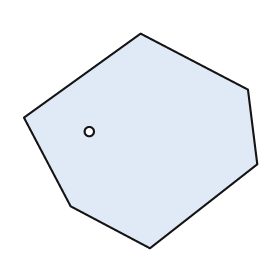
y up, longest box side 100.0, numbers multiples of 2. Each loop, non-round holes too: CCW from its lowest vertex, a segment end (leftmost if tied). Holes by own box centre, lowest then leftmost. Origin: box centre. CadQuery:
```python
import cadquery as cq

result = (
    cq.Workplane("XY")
    .moveTo(4.0, -46.0)
    .lineTo(50.0, -10.0)
    .lineTo(46.0, 22.0)
    .lineTo(0.0, 46.0)
    .lineTo(-50.0, 10.0)
    .lineTo(-30.0, -28.0)
    .close()
    .moveTo(-22.0, 4.0)
    .circle(2.0)
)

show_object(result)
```